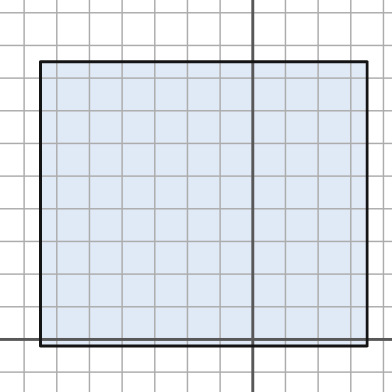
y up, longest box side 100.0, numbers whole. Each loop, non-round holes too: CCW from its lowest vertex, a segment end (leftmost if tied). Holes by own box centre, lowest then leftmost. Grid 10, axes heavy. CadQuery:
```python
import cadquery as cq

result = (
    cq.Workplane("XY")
    .moveTo(-65.0, -2.0)
    .lineTo(35.0, -2.0)
    .lineTo(35.0, 85.0)
    .lineTo(-65.0, 85.0)
    .close()
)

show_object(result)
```